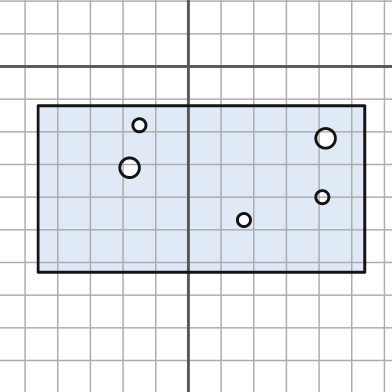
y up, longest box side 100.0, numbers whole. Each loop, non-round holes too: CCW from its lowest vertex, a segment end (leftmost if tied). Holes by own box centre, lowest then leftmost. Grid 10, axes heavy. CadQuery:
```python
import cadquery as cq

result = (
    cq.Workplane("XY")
    .moveTo(-46.0, -63.0)
    .lineTo(54.0, -63.0)
    .lineTo(54.0, -12.0)
    .lineTo(-46.0, -12.0)
    .close()
    .moveTo(17.0, -47.0)
    .circle(2.0)
    .moveTo(41.0, -40.0)
    .circle(2.0)
    .moveTo(-18.0, -31.0)
    .circle(3.0)
    .moveTo(42.0, -22.0)
    .circle(3.0)
    .moveTo(-15.0, -18.0)
    .circle(2.0)
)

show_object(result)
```